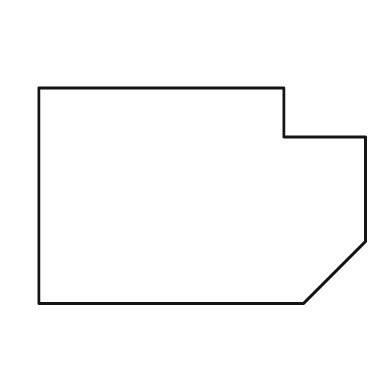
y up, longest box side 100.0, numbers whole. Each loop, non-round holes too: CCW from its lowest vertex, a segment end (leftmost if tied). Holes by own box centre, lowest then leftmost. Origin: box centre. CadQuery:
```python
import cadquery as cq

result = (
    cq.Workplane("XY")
    .moveTo(-50.0, -33.0)
    .lineTo(31.0, -33.0)
    .lineTo(50.0, -14.0)
    .lineTo(50.0, 18.0)
    .lineTo(25.0, 18.0)
    .lineTo(25.0, 33.0)
    .lineTo(-50.0, 33.0)
    .close()
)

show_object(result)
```